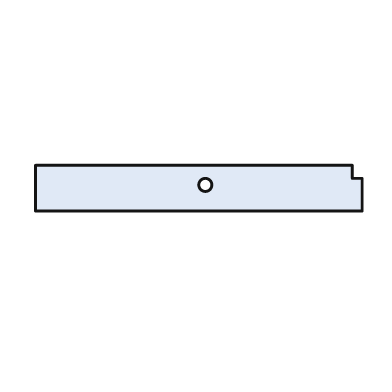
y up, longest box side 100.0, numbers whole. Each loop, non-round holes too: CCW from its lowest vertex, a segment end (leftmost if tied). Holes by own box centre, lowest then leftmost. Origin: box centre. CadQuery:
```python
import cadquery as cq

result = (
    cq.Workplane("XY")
    .moveTo(-50.0, -7.0)
    .lineTo(50.0, -7.0)
    .lineTo(50.0, 3.0)
    .lineTo(47.0, 3.0)
    .lineTo(47.0, 7.0)
    .lineTo(-50.0, 7.0)
    .close()
    .moveTo(2.0, 1.0)
    .circle(2.0)
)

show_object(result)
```